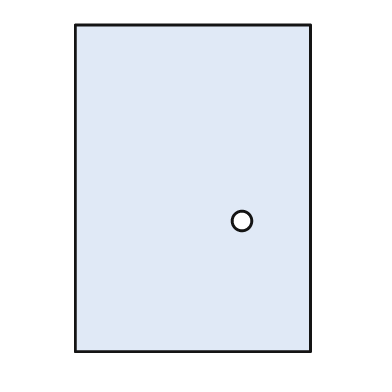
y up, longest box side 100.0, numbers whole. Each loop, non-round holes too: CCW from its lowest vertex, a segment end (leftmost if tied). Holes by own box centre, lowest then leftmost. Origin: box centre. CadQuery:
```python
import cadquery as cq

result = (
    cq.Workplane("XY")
    .moveTo(-36.0, -50.0)
    .lineTo(36.0, -50.0)
    .lineTo(36.0, 50.0)
    .lineTo(-36.0, 50.0)
    .close()
    .moveTo(15.0, -10.0)
    .circle(3.0)
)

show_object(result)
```